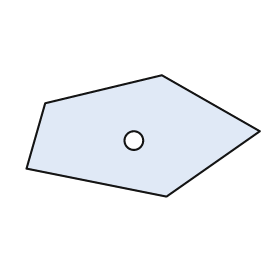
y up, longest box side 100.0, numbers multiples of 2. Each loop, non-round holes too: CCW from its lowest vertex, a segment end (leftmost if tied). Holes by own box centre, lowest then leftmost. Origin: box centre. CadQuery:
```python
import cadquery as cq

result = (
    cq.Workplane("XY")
    .moveTo(10.0, -26.0)
    .lineTo(50.0, 2.0)
    .lineTo(8.0, 26.0)
    .lineTo(-42.0, 14.0)
    .lineTo(-50.0, -14.0)
    .close()
    .moveTo(-4.0, -2.0)
    .circle(4.0)
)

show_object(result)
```